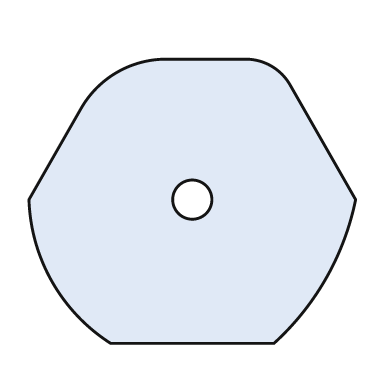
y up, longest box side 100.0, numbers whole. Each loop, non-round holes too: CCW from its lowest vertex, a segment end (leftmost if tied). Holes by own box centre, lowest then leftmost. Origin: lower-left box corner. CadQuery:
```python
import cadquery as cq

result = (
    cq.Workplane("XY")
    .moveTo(25.0, 0.0)
    .lineTo(75.0, 0.0)
    .threePointArc((91.0, 20.0), (100.0, 44.0))
    .lineTo(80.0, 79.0)
    .threePointArc((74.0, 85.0), (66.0, 87.0))
    .lineTo(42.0, 87.0)
    .threePointArc((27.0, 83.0), (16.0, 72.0))
    .lineTo(0.0, 44.0)
    .threePointArc((7.0, 19.0), (25.0, 0.0))
    .close()
    .moveTo(50.0, 44.0)
    .circle(6.0)
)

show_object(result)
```